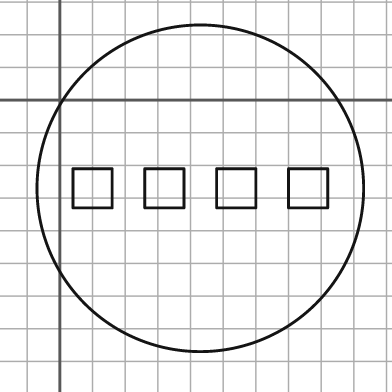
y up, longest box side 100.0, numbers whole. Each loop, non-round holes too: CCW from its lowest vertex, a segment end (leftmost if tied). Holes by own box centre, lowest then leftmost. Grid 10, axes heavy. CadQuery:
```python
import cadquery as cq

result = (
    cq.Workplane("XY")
    .moveTo(43.0, -27.0)
    .circle(50.0)
    .moveTo(4.0, -33.0)
    .lineTo(16.0, -33.0)
    .lineTo(16.0, -21.0)
    .lineTo(4.0, -21.0)
    .close()
    .moveTo(26.0, -33.0)
    .lineTo(38.0, -33.0)
    .lineTo(38.0, -21.0)
    .lineTo(26.0, -21.0)
    .close()
    .moveTo(48.0, -33.0)
    .lineTo(60.0, -33.0)
    .lineTo(60.0, -21.0)
    .lineTo(48.0, -21.0)
    .close()
    .moveTo(70.0, -33.0)
    .lineTo(82.0, -33.0)
    .lineTo(82.0, -21.0)
    .lineTo(70.0, -21.0)
    .close()
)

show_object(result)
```